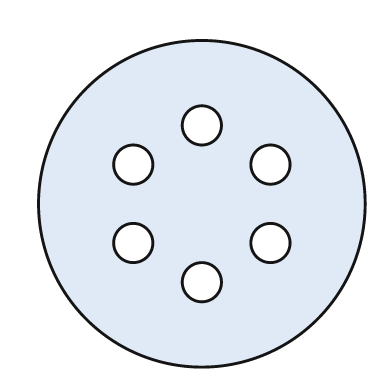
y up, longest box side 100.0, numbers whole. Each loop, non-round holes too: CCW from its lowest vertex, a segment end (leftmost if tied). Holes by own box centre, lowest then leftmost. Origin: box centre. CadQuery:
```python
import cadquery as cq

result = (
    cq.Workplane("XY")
    .moveTo(0.0, 0.0)
    .circle(50.0)
    .moveTo(0.0, -24.0)
    .circle(6.0)
    .moveTo(-21.0, -12.0)
    .circle(6.0)
    .moveTo(21.0, -12.0)
    .circle(6.0)
    .moveTo(-21.0, 12.0)
    .circle(6.0)
    .moveTo(21.0, 12.0)
    .circle(6.0)
    .moveTo(0.0, 24.0)
    .circle(6.0)
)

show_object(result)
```